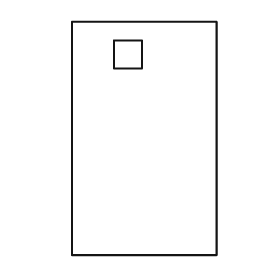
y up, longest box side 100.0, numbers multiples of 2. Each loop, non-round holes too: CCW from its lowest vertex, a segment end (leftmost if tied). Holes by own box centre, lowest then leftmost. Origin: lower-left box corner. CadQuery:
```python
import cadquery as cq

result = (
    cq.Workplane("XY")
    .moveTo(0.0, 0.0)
    .lineTo(62.0, 0.0)
    .lineTo(62.0, 100.0)
    .lineTo(0.0, 100.0)
    .close()
    .moveTo(18.0, 80.0)
    .lineTo(30.0, 80.0)
    .lineTo(30.0, 92.0)
    .lineTo(18.0, 92.0)
    .close()
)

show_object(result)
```